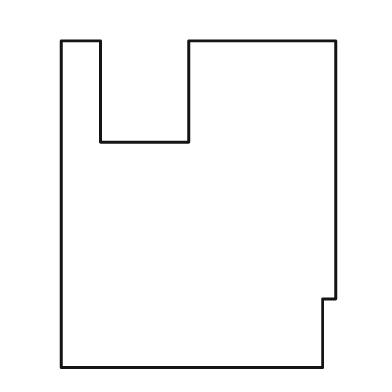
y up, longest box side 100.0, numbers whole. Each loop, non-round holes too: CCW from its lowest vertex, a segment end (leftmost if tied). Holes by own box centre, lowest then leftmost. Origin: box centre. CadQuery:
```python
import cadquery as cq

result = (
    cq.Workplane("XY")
    .moveTo(-42.0, -50.0)
    .lineTo(38.0, -50.0)
    .lineTo(38.0, -29.0)
    .lineTo(42.0, -29.0)
    .lineTo(42.0, 50.0)
    .lineTo(-3.0, 50.0)
    .lineTo(-3.0, 19.0)
    .lineTo(-30.0, 19.0)
    .lineTo(-30.0, 50.0)
    .lineTo(-42.0, 50.0)
    .close()
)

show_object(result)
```